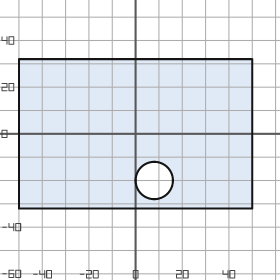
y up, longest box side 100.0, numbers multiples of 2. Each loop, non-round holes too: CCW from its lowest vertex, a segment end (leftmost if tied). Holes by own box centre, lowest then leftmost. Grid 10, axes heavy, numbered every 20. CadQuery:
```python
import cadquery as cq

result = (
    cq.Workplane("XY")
    .moveTo(-50.0, -32.0)
    .lineTo(50.0, -32.0)
    .lineTo(50.0, 32.0)
    .lineTo(-50.0, 32.0)
    .close()
    .moveTo(8.0, -20.0)
    .circle(8.0)
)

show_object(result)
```